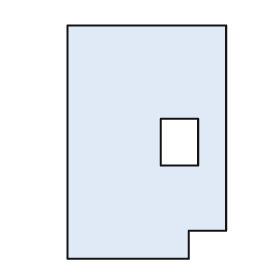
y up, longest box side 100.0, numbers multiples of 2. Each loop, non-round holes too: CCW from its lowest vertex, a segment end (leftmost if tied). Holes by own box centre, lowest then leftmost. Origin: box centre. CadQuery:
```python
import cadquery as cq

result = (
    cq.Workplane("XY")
    .moveTo(-34.0, -50.0)
    .lineTo(18.0, -50.0)
    .lineTo(18.0, -38.0)
    .lineTo(34.0, -38.0)
    .lineTo(34.0, 50.0)
    .lineTo(-34.0, 50.0)
    .close()
    .moveTo(6.0, -10.0)
    .lineTo(22.0, -10.0)
    .lineTo(22.0, 10.0)
    .lineTo(6.0, 10.0)
    .close()
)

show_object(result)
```